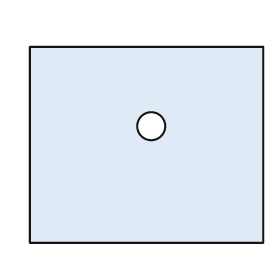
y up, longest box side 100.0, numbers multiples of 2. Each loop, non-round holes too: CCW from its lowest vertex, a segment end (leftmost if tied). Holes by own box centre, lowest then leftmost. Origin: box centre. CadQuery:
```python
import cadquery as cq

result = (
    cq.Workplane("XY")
    .moveTo(-50.0, -42.0)
    .lineTo(50.0, -42.0)
    .lineTo(50.0, 42.0)
    .lineTo(-50.0, 42.0)
    .close()
    .moveTo(2.0, 8.0)
    .circle(6.0)
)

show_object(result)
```